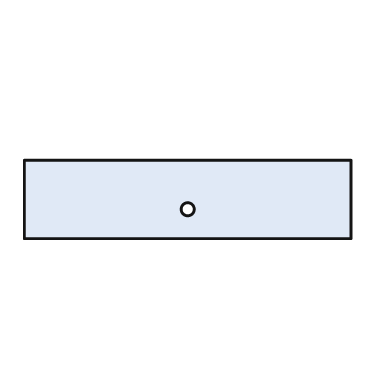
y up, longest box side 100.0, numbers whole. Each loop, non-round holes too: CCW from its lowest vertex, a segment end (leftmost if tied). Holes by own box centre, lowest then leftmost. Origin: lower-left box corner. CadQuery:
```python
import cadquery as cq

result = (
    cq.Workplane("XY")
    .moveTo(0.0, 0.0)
    .lineTo(100.0, 0.0)
    .lineTo(100.0, 24.0)
    .lineTo(0.0, 24.0)
    .close()
    .moveTo(50.0, 9.0)
    .circle(2.0)
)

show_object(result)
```